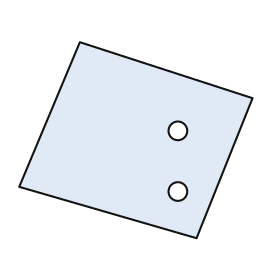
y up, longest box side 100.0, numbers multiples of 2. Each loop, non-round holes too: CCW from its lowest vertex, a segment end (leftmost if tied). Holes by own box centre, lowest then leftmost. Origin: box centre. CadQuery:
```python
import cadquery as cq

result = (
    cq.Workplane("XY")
    .moveTo(26.0, -42.0)
    .lineTo(50.0, 18.0)
    .lineTo(-24.0, 42.0)
    .lineTo(-50.0, -20.0)
    .close()
    .moveTo(18.0, -22.0)
    .circle(4.0)
    .moveTo(18.0, 4.0)
    .circle(4.0)
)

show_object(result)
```